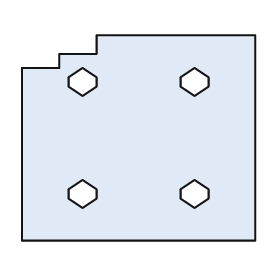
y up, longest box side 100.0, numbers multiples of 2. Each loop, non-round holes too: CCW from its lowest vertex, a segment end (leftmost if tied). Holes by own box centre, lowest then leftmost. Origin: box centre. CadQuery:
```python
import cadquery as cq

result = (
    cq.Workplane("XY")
    .moveTo(-50.0, -44.0)
    .lineTo(50.0, -44.0)
    .lineTo(50.0, 44.0)
    .lineTo(-18.0, 44.0)
    .lineTo(-18.0, 36.0)
    .lineTo(-34.0, 36.0)
    .lineTo(-34.0, 30.0)
    .lineTo(-50.0, 30.0)
    .close()
    .moveTo(-24.0, -30.0)
    .lineTo(-18.0, -26.0)
    .lineTo(-18.0, -22.0)
    .lineTo(-24.0, -18.0)
    .lineTo(-30.0, -22.0)
    .lineTo(-30.0, -26.0)
    .close()
    .moveTo(24.0, -30.0)
    .lineTo(30.0, -26.0)
    .lineTo(30.0, -22.0)
    .lineTo(24.0, -18.0)
    .lineTo(18.0, -22.0)
    .lineTo(18.0, -26.0)
    .close()
    .moveTo(-24.0, 18.0)
    .lineTo(-18.0, 22.0)
    .lineTo(-18.0, 26.0)
    .lineTo(-24.0, 30.0)
    .lineTo(-30.0, 26.0)
    .lineTo(-30.0, 22.0)
    .close()
    .moveTo(24.0, 18.0)
    .lineTo(30.0, 22.0)
    .lineTo(30.0, 26.0)
    .lineTo(24.0, 30.0)
    .lineTo(18.0, 26.0)
    .lineTo(18.0, 22.0)
    .close()
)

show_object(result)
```